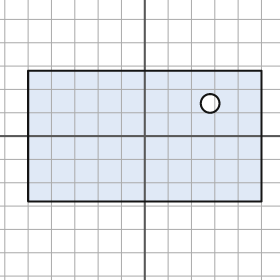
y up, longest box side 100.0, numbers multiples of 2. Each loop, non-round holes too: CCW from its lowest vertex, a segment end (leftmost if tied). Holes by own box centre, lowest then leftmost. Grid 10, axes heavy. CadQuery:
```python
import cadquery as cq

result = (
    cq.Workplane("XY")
    .moveTo(-50.0, -28.0)
    .lineTo(50.0, -28.0)
    .lineTo(50.0, 28.0)
    .lineTo(-50.0, 28.0)
    .close()
    .moveTo(28.0, 14.0)
    .circle(4.0)
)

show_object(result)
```